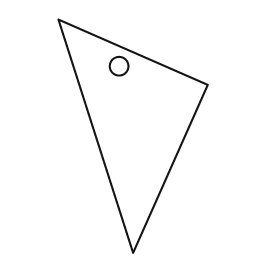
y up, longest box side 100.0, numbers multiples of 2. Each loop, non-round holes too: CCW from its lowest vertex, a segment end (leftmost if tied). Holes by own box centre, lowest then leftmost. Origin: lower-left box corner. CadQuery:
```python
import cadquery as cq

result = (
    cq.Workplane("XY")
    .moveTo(32.0, 0.0)
    .lineTo(64.0, 72.0)
    .lineTo(0.0, 100.0)
    .close()
    .moveTo(26.0, 80.0)
    .circle(4.0)
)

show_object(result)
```